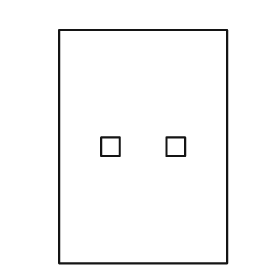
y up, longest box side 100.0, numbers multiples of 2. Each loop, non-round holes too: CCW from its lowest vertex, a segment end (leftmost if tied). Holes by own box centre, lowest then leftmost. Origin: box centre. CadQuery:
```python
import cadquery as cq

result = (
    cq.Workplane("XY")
    .moveTo(-36.0, -50.0)
    .lineTo(36.0, -50.0)
    .lineTo(36.0, 50.0)
    .lineTo(-36.0, 50.0)
    .close()
    .moveTo(-18.0, -4.0)
    .lineTo(-10.0, -4.0)
    .lineTo(-10.0, 4.0)
    .lineTo(-18.0, 4.0)
    .close()
    .moveTo(10.0, -4.0)
    .lineTo(18.0, -4.0)
    .lineTo(18.0, 4.0)
    .lineTo(10.0, 4.0)
    .close()
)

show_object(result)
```